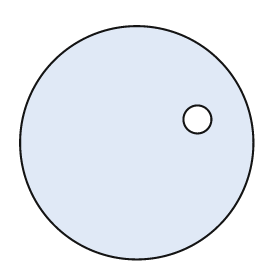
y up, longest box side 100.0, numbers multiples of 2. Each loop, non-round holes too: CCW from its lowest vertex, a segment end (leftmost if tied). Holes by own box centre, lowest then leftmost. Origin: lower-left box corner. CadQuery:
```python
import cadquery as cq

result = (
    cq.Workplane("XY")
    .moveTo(50.0, 50.0)
    .circle(50.0)
    .moveTo(76.0, 60.0)
    .circle(6.0)
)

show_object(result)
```